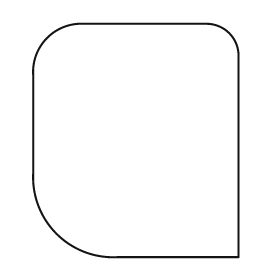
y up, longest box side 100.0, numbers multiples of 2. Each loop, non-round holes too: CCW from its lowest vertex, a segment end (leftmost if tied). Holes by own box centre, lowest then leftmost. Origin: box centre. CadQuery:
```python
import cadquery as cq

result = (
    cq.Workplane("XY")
    .moveTo(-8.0, -50.0)
    .lineTo(44.0, -50.0)
    .lineTo(44.0, 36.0)
    .threePointArc((40.0, 46.0), (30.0, 50.0))
    .lineTo(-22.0, 50.0)
    .threePointArc((-38.0, 44.0), (-44.0, 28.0))
    .lineTo(-44.0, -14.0)
    .threePointArc((-34.0, -40.0), (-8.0, -50.0))
    .close()
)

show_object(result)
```